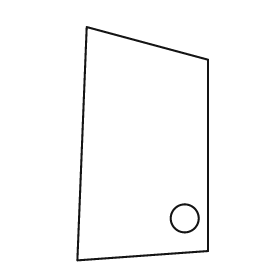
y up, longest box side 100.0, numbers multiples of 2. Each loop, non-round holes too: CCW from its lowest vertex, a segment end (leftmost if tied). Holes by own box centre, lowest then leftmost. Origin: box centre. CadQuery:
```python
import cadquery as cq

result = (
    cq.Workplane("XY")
    .moveTo(-28.0, -50.0)
    .lineTo(28.0, -46.0)
    .lineTo(28.0, 36.0)
    .lineTo(-24.0, 50.0)
    .close()
    .moveTo(18.0, -32.0)
    .circle(6.0)
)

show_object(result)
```